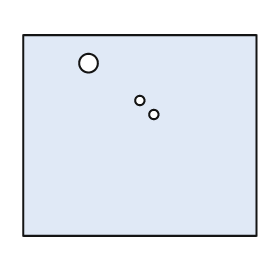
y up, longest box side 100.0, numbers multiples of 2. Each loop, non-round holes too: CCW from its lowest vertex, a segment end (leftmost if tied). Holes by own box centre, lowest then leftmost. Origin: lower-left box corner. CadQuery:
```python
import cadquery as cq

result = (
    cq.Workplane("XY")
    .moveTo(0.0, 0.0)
    .lineTo(100.0, 0.0)
    .lineTo(100.0, 86.0)
    .lineTo(0.0, 86.0)
    .close()
    .moveTo(56.0, 52.0)
    .circle(2.0)
    .moveTo(50.0, 58.0)
    .circle(2.0)
    .moveTo(28.0, 74.0)
    .circle(4.0)
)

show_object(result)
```